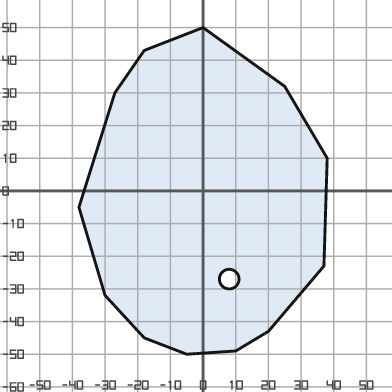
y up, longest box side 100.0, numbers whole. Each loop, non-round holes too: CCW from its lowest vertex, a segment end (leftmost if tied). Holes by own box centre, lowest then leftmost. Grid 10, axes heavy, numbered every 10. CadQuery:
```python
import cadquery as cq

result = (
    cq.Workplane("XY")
    .moveTo(-5.0, -50.0)
    .lineTo(10.0, -49.0)
    .lineTo(20.0, -43.0)
    .lineTo(37.0, -23.0)
    .lineTo(38.0, 10.0)
    .lineTo(25.0, 32.0)
    .lineTo(0.0, 50.0)
    .lineTo(-18.0, 43.0)
    .lineTo(-27.0, 30.0)
    .lineTo(-38.0, -5.0)
    .lineTo(-30.0, -32.0)
    .lineTo(-18.0, -45.0)
    .close()
    .moveTo(8.0, -27.0)
    .circle(3.0)
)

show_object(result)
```